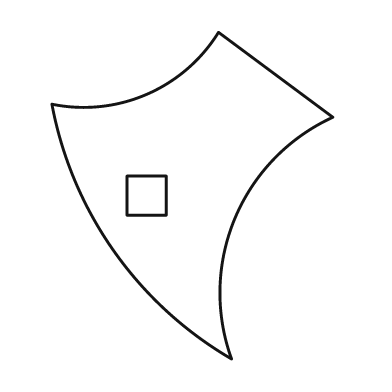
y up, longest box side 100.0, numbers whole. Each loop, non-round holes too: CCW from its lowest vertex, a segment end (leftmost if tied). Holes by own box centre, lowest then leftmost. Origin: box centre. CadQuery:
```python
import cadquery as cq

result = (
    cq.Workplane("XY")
    .moveTo(12.0, -50.0)
    .threePointArc((13.0, -7.0), (43.0, 24.0))
    .lineTo(8.0, 50.0)
    .threePointArc((-14.0, 31.0), (-43.0, 28.0))
    .threePointArc((-24.0, -17.0), (12.0, -50.0))
    .close()
    .moveTo(-20.0, -6.0)
    .lineTo(-8.0, -6.0)
    .lineTo(-8.0, 6.0)
    .lineTo(-20.0, 6.0)
    .close()
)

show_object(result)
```